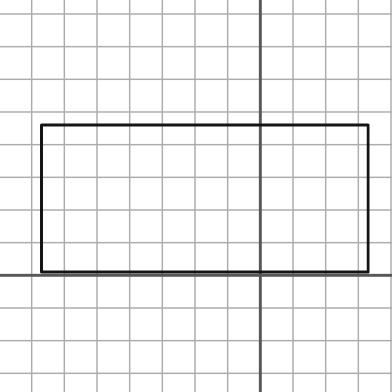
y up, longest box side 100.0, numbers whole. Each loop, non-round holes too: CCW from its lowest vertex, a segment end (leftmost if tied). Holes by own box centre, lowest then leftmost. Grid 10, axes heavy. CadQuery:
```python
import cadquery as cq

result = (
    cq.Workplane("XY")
    .moveTo(-67.0, 1.0)
    .lineTo(33.0, 1.0)
    .lineTo(33.0, 46.0)
    .lineTo(-67.0, 46.0)
    .close()
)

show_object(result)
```